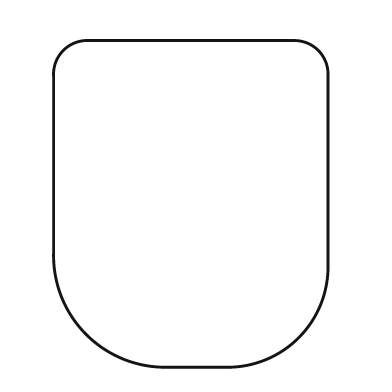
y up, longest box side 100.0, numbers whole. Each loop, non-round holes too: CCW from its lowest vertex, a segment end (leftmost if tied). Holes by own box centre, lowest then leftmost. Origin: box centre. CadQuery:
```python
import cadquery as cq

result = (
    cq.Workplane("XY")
    .moveTo(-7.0, -50.0)
    .lineTo(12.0, -50.0)
    .threePointArc((33.0, -41.0), (42.0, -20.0))
    .lineTo(42.0, 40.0)
    .threePointArc((39.0, 47.0), (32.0, 50.0))
    .lineTo(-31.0, 50.0)
    .threePointArc((-39.0, 47.0), (-42.0, 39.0))
    .lineTo(-42.0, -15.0)
    .threePointArc((-32.0, -40.0), (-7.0, -50.0))
    .close()
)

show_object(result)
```